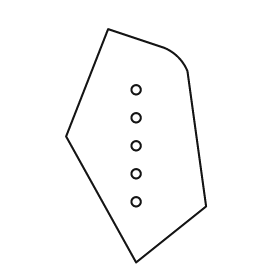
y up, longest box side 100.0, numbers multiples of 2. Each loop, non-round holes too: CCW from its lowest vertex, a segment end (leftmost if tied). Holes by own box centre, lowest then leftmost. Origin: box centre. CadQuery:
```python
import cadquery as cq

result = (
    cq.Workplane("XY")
    .moveTo(0.0, -50.0)
    .lineTo(30.0, -26.0)
    .lineTo(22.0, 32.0)
    .threePointArc((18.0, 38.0), (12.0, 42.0))
    .lineTo(-12.0, 50.0)
    .lineTo(-30.0, 4.0)
    .close()
    .moveTo(0.0, -24.0)
    .circle(2.0)
    .moveTo(0.0, -12.0)
    .circle(2.0)
    .moveTo(0.0, 0.0)
    .circle(2.0)
    .moveTo(0.0, 12.0)
    .circle(2.0)
    .moveTo(0.0, 24.0)
    .circle(2.0)
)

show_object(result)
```